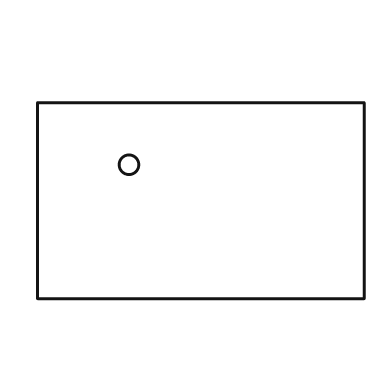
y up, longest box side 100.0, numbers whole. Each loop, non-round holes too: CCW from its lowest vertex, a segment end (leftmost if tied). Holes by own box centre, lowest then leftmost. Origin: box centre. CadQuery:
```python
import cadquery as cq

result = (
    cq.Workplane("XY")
    .moveTo(-50.0, -30.0)
    .lineTo(50.0, -30.0)
    .lineTo(50.0, 30.0)
    .lineTo(-50.0, 30.0)
    .close()
    .moveTo(-22.0, 11.0)
    .circle(3.0)
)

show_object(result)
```